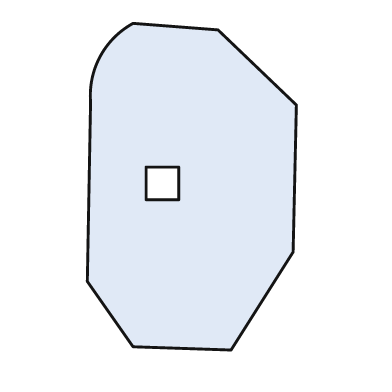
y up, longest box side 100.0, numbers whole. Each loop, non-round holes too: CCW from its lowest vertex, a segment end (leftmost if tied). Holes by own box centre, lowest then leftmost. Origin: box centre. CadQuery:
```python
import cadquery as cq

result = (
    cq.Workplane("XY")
    .moveTo(12.0, -50.0)
    .lineTo(31.0, -20.0)
    .lineTo(32.0, 25.0)
    .lineTo(8.0, 48.0)
    .lineTo(-18.0, 50.0)
    .threePointArc((-28.0, 40.0), (-31.0, 26.0))
    .lineTo(-32.0, -29.0)
    .lineTo(-18.0, -49.0)
    .close()
    .moveTo(-14.0, -4.0)
    .lineTo(-4.0, -4.0)
    .lineTo(-4.0, 6.0)
    .lineTo(-14.0, 6.0)
    .close()
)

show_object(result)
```